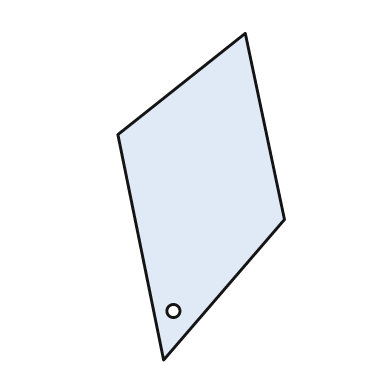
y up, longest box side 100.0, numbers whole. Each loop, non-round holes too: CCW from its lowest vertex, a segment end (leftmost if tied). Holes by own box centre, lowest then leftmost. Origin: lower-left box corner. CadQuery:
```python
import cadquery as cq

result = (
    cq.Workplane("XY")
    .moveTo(14.0, 0.0)
    .lineTo(51.0, 43.0)
    .lineTo(39.0, 100.0)
    .lineTo(0.0, 69.0)
    .close()
    .moveTo(17.0, 15.0)
    .circle(2.0)
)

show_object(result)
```